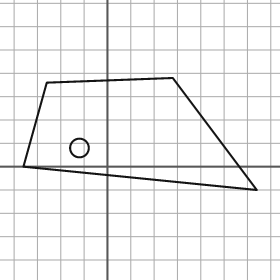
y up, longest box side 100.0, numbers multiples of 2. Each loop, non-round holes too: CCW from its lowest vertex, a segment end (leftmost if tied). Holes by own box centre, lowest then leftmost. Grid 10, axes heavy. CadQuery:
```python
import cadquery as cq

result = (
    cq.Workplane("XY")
    .moveTo(64.0, -10.0)
    .lineTo(28.0, 38.0)
    .lineTo(-26.0, 36.0)
    .lineTo(-36.0, 0.0)
    .close()
    .moveTo(-12.0, 8.0)
    .circle(4.0)
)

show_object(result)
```